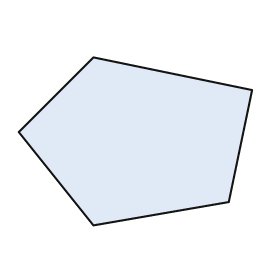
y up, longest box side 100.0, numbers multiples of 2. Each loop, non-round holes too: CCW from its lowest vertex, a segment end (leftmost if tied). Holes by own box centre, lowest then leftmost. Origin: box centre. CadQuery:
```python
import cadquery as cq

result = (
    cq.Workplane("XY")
    .moveTo(-18.0, -36.0)
    .lineTo(40.0, -26.0)
    .lineTo(50.0, 22.0)
    .lineTo(-18.0, 36.0)
    .lineTo(-50.0, 4.0)
    .close()
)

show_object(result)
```